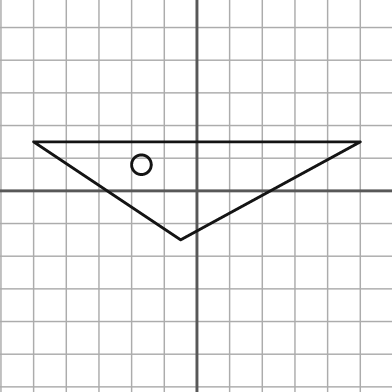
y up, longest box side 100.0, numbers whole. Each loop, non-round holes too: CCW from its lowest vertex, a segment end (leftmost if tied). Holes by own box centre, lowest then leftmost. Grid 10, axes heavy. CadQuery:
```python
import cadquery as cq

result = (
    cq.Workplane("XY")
    .moveTo(-5.0, -15.0)
    .lineTo(50.0, 15.0)
    .lineTo(-50.0, 15.0)
    .close()
    .moveTo(-17.0, 8.0)
    .circle(3.0)
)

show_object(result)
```